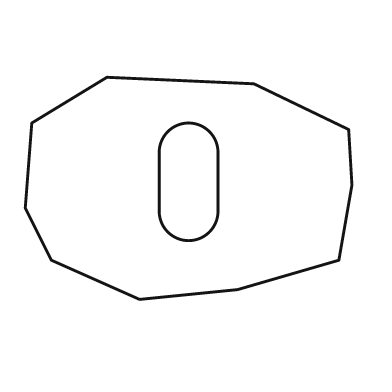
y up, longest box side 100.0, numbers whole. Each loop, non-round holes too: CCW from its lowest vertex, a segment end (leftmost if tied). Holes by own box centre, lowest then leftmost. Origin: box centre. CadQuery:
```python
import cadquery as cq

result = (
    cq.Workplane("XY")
    .moveTo(-15.0, -34.0)
    .lineTo(15.0, -31.0)
    .lineTo(46.0, -22.0)
    .lineTo(50.0, 1.0)
    .lineTo(49.0, 18.0)
    .lineTo(20.0, 32.0)
    .lineTo(-25.0, 34.0)
    .lineTo(-48.0, 20.0)
    .lineTo(-50.0, -6.0)
    .lineTo(-42.0, -22.0)
    .close()
    .moveTo(-9.0, -7.0)
    .threePointArc((0.0, -16.0), (9.0, -7.0))
    .lineTo(9.0, 11.0)
    .threePointArc((0.0, 20.0), (-9.0, 11.0))
    .close()
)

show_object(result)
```